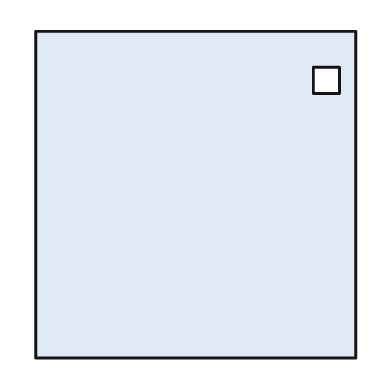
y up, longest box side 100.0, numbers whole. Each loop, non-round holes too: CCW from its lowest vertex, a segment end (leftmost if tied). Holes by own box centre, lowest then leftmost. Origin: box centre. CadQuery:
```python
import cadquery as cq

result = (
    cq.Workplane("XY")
    .moveTo(-49.0, -50.0)
    .lineTo(49.0, -50.0)
    .lineTo(49.0, 50.0)
    .lineTo(-49.0, 50.0)
    .close()
    .moveTo(36.0, 31.0)
    .lineTo(44.0, 31.0)
    .lineTo(44.0, 39.0)
    .lineTo(36.0, 39.0)
    .close()
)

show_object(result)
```